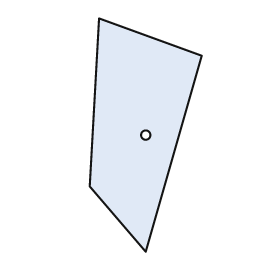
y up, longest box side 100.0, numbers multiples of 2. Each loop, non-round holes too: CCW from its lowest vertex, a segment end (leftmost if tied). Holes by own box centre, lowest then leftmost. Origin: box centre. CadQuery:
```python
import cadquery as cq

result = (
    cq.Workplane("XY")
    .moveTo(0.0, -50.0)
    .lineTo(24.0, 34.0)
    .lineTo(-20.0, 50.0)
    .lineTo(-24.0, -22.0)
    .close()
    .moveTo(0.0, 0.0)
    .circle(2.0)
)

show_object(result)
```